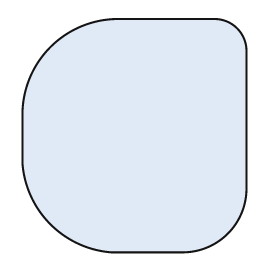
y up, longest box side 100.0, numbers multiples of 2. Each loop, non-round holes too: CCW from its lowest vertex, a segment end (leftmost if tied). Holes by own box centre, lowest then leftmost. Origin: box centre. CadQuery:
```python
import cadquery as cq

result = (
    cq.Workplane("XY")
    .moveTo(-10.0, -50.0)
    .lineTo(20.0, -50.0)
    .threePointArc((40.0, -42.0), (48.0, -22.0))
    .lineTo(48.0, 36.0)
    .threePointArc((44.0, 46.0), (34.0, 50.0))
    .lineTo(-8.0, 50.0)
    .threePointArc((-36.0, 38.0), (-48.0, 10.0))
    .lineTo(-48.0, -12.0)
    .threePointArc((-36.0, -38.0), (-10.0, -50.0))
    .close()
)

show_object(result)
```